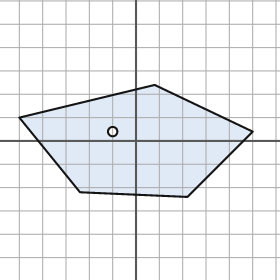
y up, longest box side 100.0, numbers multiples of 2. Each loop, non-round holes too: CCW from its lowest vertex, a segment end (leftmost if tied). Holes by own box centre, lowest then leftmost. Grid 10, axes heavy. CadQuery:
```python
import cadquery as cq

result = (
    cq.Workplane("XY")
    .moveTo(22.0, -24.0)
    .lineTo(50.0, 4.0)
    .lineTo(8.0, 24.0)
    .lineTo(-50.0, 10.0)
    .lineTo(-24.0, -22.0)
    .close()
    .moveTo(-10.0, 4.0)
    .circle(2.0)
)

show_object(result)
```